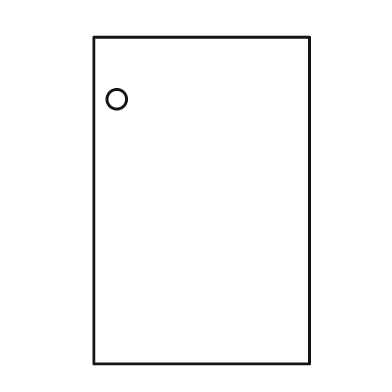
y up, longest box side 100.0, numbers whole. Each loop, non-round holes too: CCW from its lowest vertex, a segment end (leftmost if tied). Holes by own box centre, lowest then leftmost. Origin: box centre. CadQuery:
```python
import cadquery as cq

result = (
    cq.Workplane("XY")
    .moveTo(-33.0, -50.0)
    .lineTo(33.0, -50.0)
    .lineTo(33.0, 50.0)
    .lineTo(-33.0, 50.0)
    .close()
    .moveTo(-26.0, 31.0)
    .circle(3.0)
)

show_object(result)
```